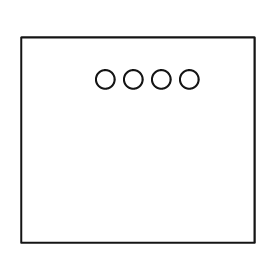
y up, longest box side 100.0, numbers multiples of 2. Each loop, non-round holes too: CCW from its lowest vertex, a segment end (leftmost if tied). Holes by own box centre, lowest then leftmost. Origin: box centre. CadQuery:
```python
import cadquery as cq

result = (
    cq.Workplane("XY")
    .moveTo(-50.0, -44.0)
    .lineTo(50.0, -44.0)
    .lineTo(50.0, 44.0)
    .lineTo(-50.0, 44.0)
    .close()
    .moveTo(-14.0, 26.0)
    .circle(4.0)
    .moveTo(-2.0, 26.0)
    .circle(4.0)
    .moveTo(10.0, 26.0)
    .circle(4.0)
    .moveTo(22.0, 26.0)
    .circle(4.0)
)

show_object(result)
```